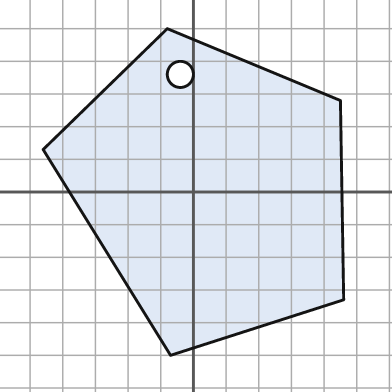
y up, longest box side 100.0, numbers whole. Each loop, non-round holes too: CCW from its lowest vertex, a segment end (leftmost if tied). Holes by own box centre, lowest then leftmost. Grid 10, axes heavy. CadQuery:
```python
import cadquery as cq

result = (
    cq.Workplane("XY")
    .moveTo(-7.0, -50.0)
    .lineTo(46.0, -33.0)
    .lineTo(45.0, 28.0)
    .lineTo(-8.0, 50.0)
    .lineTo(-46.0, 13.0)
    .close()
    .moveTo(-4.0, 36.0)
    .circle(4.0)
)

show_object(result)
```